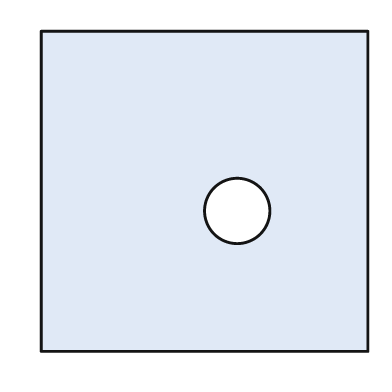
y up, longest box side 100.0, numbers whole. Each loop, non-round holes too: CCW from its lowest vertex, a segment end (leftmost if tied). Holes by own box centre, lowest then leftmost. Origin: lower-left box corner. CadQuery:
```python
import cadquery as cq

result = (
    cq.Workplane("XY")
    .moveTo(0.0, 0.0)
    .lineTo(100.0, 0.0)
    .lineTo(100.0, 98.0)
    .lineTo(0.0, 98.0)
    .close()
    .moveTo(60.0, 43.0)
    .circle(10.0)
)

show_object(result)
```